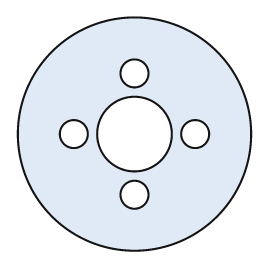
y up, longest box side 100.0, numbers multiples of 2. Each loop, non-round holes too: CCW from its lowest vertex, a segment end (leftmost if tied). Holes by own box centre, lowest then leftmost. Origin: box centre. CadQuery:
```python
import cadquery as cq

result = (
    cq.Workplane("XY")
    .moveTo(0.0, 0.0)
    .circle(50.0)
    .moveTo(0.0, -26.0)
    .circle(6.0)
    .moveTo(-26.0, 0.0)
    .circle(6.0)
    .moveTo(0.0, 0.0)
    .circle(16.0)
    .moveTo(26.0, 0.0)
    .circle(6.0)
    .moveTo(0.0, 26.0)
    .circle(6.0)
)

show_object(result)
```